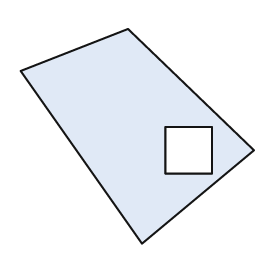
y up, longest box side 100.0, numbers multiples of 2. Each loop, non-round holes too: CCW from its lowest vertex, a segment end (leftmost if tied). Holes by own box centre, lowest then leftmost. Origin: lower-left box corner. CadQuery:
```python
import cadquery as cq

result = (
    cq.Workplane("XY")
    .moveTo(52.0, 0.0)
    .lineTo(100.0, 40.0)
    .lineTo(46.0, 92.0)
    .lineTo(0.0, 74.0)
    .close()
    .moveTo(62.0, 30.0)
    .lineTo(82.0, 30.0)
    .lineTo(82.0, 50.0)
    .lineTo(62.0, 50.0)
    .close()
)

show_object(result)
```